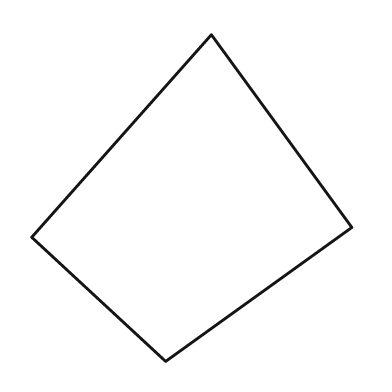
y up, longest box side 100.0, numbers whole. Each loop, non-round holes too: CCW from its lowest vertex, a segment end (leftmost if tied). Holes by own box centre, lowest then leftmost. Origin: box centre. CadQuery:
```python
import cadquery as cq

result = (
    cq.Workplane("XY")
    .moveTo(-8.0, -50.0)
    .lineTo(49.0, -9.0)
    .lineTo(6.0, 50.0)
    .lineTo(-49.0, -12.0)
    .close()
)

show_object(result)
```